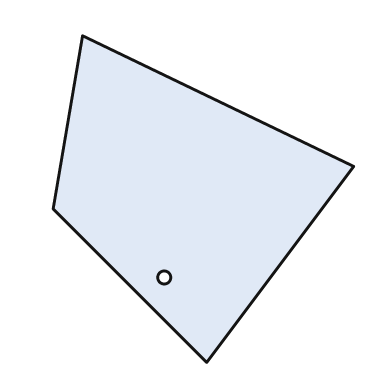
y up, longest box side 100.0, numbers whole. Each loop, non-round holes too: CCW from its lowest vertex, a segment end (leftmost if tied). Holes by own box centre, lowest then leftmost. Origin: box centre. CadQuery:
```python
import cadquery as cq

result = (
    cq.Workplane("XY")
    .moveTo(1.0, -50.0)
    .lineTo(46.0, 10.0)
    .lineTo(-37.0, 50.0)
    .lineTo(-46.0, -3.0)
    .close()
    .moveTo(-12.0, -24.0)
    .circle(2.0)
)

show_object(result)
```